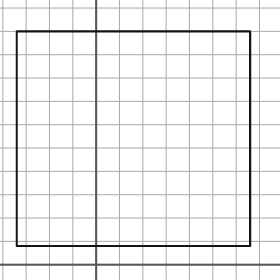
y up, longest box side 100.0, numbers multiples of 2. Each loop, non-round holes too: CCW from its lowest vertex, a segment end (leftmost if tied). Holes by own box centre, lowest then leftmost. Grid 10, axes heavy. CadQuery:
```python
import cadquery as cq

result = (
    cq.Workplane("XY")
    .moveTo(-34.0, 8.0)
    .lineTo(66.0, 8.0)
    .lineTo(66.0, 100.0)
    .lineTo(-34.0, 100.0)
    .close()
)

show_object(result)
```